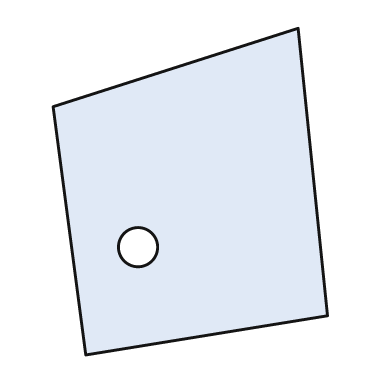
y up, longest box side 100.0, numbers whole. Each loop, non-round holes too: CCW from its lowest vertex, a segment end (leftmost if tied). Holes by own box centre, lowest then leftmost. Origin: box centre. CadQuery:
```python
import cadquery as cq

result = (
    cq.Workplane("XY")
    .moveTo(-32.0, -50.0)
    .lineTo(42.0, -38.0)
    .lineTo(33.0, 50.0)
    .lineTo(-42.0, 26.0)
    .close()
    .moveTo(-16.0, -17.0)
    .circle(6.0)
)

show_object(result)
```